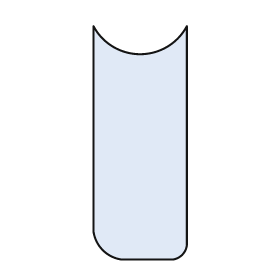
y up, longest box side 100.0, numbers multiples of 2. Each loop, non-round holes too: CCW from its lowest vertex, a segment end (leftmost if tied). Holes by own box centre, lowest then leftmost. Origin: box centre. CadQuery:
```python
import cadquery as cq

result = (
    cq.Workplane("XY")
    .moveTo(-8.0, -50.0)
    .lineTo(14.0, -50.0)
    .threePointArc((18.0, -48.0), (20.0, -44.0))
    .lineTo(20.0, 50.0)
    .threePointArc((0.0, 38.0), (-20.0, 50.0))
    .lineTo(-20.0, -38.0)
    .threePointArc((-16.0, -46.0), (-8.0, -50.0))
    .close()
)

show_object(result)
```